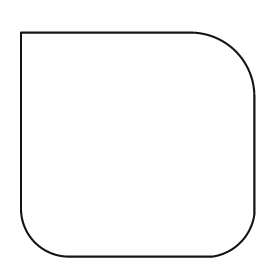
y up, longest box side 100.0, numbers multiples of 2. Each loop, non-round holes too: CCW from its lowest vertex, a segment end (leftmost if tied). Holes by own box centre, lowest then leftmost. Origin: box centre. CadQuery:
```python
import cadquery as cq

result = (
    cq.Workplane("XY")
    .moveTo(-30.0, -48.0)
    .lineTo(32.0, -48.0)
    .threePointArc((44.0, -42.0), (50.0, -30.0))
    .lineTo(50.0, 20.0)
    .threePointArc((42.0, 40.0), (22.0, 48.0))
    .lineTo(-50.0, 48.0)
    .lineTo(-50.0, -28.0)
    .threePointArc((-44.0, -42.0), (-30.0, -48.0))
    .close()
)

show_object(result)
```